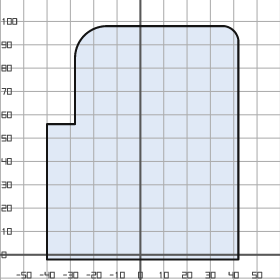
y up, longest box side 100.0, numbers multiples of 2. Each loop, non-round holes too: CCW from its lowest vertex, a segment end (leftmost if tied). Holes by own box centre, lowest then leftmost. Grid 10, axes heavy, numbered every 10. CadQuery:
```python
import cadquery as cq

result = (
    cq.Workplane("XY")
    .moveTo(-40.0, -2.0)
    .lineTo(42.0, -2.0)
    .lineTo(42.0, 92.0)
    .threePointArc((40.0, 96.0), (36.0, 98.0))
    .lineTo(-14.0, 98.0)
    .threePointArc((-24.0, 94.0), (-28.0, 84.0))
    .lineTo(-28.0, 56.0)
    .lineTo(-40.0, 56.0)
    .close()
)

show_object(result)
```